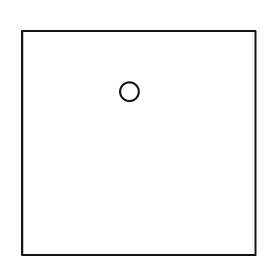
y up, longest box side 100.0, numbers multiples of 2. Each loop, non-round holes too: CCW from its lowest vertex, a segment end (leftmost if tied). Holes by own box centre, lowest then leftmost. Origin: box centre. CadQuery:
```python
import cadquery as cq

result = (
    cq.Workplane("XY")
    .moveTo(-50.0, -48.0)
    .lineTo(50.0, -48.0)
    .lineTo(50.0, 48.0)
    .lineTo(-50.0, 48.0)
    .close()
    .moveTo(-4.0, 22.0)
    .circle(4.0)
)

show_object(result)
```